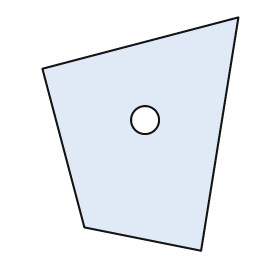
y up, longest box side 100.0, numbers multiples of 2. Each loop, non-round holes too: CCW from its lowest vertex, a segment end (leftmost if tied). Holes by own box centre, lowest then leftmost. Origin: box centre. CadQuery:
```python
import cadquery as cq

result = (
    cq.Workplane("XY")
    .moveTo(26.0, -50.0)
    .lineTo(42.0, 50.0)
    .lineTo(-42.0, 28.0)
    .lineTo(-24.0, -40.0)
    .close()
    .moveTo(2.0, 6.0)
    .circle(6.0)
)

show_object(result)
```